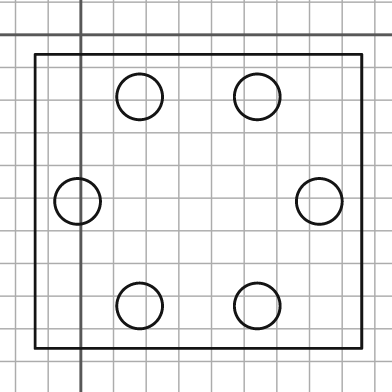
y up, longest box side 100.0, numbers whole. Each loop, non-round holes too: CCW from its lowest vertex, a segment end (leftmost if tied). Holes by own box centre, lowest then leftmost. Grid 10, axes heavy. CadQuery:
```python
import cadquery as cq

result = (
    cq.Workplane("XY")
    .moveTo(-14.0, -96.0)
    .lineTo(86.0, -96.0)
    .lineTo(86.0, -6.0)
    .lineTo(-14.0, -6.0)
    .close()
    .moveTo(18.0, -83.0)
    .circle(7.0)
    .moveTo(54.0, -83.0)
    .circle(7.0)
    .moveTo(-1.0, -51.0)
    .circle(7.0)
    .moveTo(73.0, -51.0)
    .circle(7.0)
    .moveTo(18.0, -19.0)
    .circle(7.0)
    .moveTo(54.0, -19.0)
    .circle(7.0)
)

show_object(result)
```